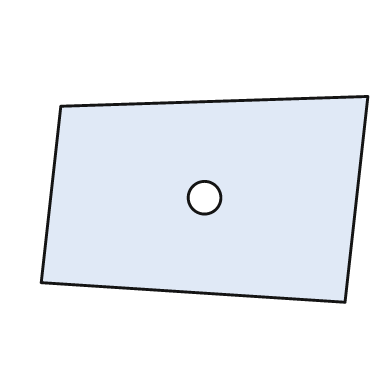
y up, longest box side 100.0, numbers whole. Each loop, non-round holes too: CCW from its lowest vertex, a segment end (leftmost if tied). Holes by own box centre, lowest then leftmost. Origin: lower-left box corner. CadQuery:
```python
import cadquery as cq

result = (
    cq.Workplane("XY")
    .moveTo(93.0, 0.0)
    .lineTo(100.0, 63.0)
    .lineTo(6.0, 60.0)
    .lineTo(0.0, 6.0)
    .close()
    .moveTo(50.0, 32.0)
    .circle(5.0)
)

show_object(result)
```